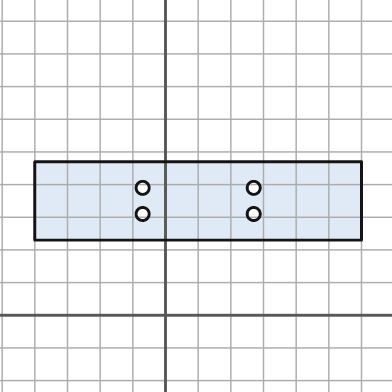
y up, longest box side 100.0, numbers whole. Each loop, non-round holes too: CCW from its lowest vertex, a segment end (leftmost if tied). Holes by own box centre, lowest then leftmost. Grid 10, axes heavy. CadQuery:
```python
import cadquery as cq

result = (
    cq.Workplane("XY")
    .moveTo(-40.0, 23.0)
    .lineTo(60.0, 23.0)
    .lineTo(60.0, 47.0)
    .lineTo(-40.0, 47.0)
    .close()
    .moveTo(-7.0, 31.0)
    .circle(2.0)
    .moveTo(27.0, 31.0)
    .circle(2.0)
    .moveTo(-7.0, 39.0)
    .circle(2.0)
    .moveTo(27.0, 39.0)
    .circle(2.0)
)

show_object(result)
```